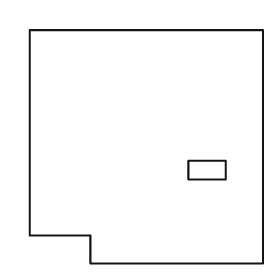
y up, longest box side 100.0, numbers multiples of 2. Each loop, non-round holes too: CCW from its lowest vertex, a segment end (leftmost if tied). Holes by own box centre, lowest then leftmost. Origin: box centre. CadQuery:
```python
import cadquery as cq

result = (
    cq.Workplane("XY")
    .moveTo(-24.0, -50.0)
    .lineTo(50.0, -50.0)
    .lineTo(50.0, 50.0)
    .lineTo(-50.0, 50.0)
    .lineTo(-50.0, -38.0)
    .lineTo(-24.0, -38.0)
    .close()
    .moveTo(18.0, -14.0)
    .lineTo(34.0, -14.0)
    .lineTo(34.0, -6.0)
    .lineTo(18.0, -6.0)
    .close()
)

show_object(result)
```